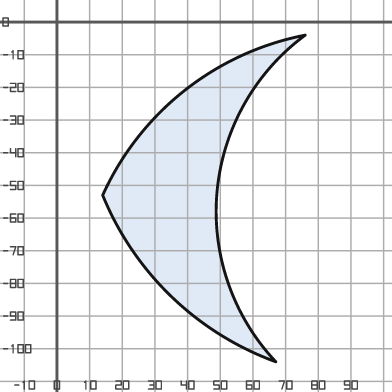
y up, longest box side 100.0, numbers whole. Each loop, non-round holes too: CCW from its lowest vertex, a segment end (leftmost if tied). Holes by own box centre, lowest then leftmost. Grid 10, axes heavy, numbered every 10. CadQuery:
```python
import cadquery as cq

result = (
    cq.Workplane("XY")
    .moveTo(67.0, -104.0)
    .threePointArc((49.0, -52.0), (76.0, -4.0))
    .threePointArc((39.0, -21.0), (14.0, -53.0))
    .threePointArc((35.0, -84.0), (67.0, -104.0))
    .close()
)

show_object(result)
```